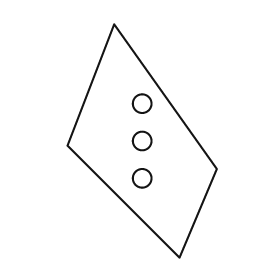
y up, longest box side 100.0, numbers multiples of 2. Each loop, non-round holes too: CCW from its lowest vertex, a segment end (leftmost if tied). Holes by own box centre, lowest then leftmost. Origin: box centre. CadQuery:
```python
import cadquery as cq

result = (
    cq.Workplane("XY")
    .moveTo(16.0, -50.0)
    .lineTo(32.0, -12.0)
    .lineTo(-12.0, 50.0)
    .lineTo(-32.0, -2.0)
    .close()
    .moveTo(0.0, -16.0)
    .circle(4.0)
    .moveTo(0.0, 0.0)
    .circle(4.0)
    .moveTo(0.0, 16.0)
    .circle(4.0)
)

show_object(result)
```